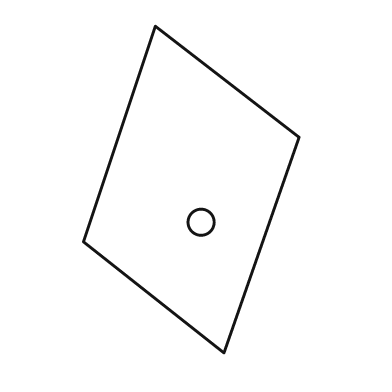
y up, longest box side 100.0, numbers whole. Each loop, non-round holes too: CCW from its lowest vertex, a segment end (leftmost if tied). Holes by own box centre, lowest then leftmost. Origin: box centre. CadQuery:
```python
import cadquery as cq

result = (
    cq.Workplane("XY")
    .moveTo(10.0, -50.0)
    .lineTo(33.0, 16.0)
    .lineTo(-11.0, 50.0)
    .lineTo(-33.0, -16.0)
    .close()
    .moveTo(3.0, -10.0)
    .circle(4.0)
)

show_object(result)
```